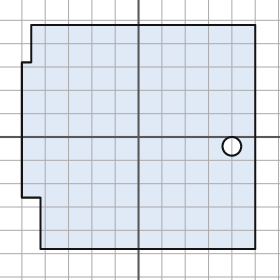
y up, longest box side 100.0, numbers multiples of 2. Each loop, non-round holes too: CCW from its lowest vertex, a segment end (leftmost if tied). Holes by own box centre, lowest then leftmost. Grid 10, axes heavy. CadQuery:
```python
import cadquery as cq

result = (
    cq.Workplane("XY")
    .moveTo(-42.0, -48.0)
    .lineTo(50.0, -48.0)
    .lineTo(50.0, 48.0)
    .lineTo(-46.0, 48.0)
    .lineTo(-46.0, 32.0)
    .lineTo(-50.0, 32.0)
    .lineTo(-50.0, -26.0)
    .lineTo(-42.0, -26.0)
    .close()
    .moveTo(40.0, -4.0)
    .circle(4.0)
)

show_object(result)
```